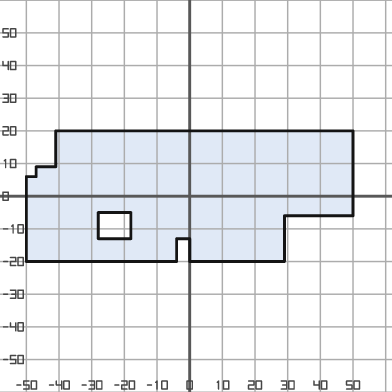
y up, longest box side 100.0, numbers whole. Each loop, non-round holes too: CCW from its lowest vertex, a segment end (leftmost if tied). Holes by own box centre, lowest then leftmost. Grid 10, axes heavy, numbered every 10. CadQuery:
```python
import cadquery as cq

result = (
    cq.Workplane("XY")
    .moveTo(-50.0, -20.0)
    .lineTo(-4.0, -20.0)
    .lineTo(-4.0, -13.0)
    .lineTo(0.0, -13.0)
    .lineTo(0.0, -20.0)
    .lineTo(29.0, -20.0)
    .lineTo(29.0, -6.0)
    .lineTo(50.0, -6.0)
    .lineTo(50.0, 20.0)
    .lineTo(-41.0, 20.0)
    .lineTo(-41.0, 9.0)
    .lineTo(-47.0, 9.0)
    .lineTo(-47.0, 6.0)
    .lineTo(-50.0, 6.0)
    .close()
    .moveTo(-28.0, -13.0)
    .lineTo(-18.0, -13.0)
    .lineTo(-18.0, -5.0)
    .lineTo(-28.0, -5.0)
    .close()
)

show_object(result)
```